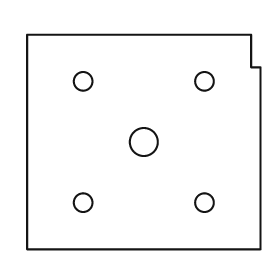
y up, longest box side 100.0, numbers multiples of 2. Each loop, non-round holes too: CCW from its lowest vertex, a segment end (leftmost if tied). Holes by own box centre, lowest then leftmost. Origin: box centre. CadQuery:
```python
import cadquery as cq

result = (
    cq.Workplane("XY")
    .moveTo(-50.0, -46.0)
    .lineTo(50.0, -46.0)
    .lineTo(50.0, 32.0)
    .lineTo(46.0, 32.0)
    .lineTo(46.0, 46.0)
    .lineTo(-50.0, 46.0)
    .close()
    .moveTo(-26.0, -26.0)
    .circle(4.0)
    .moveTo(26.0, -26.0)
    .circle(4.0)
    .moveTo(0.0, 0.0)
    .circle(6.0)
    .moveTo(-26.0, 26.0)
    .circle(4.0)
    .moveTo(26.0, 26.0)
    .circle(4.0)
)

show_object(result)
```